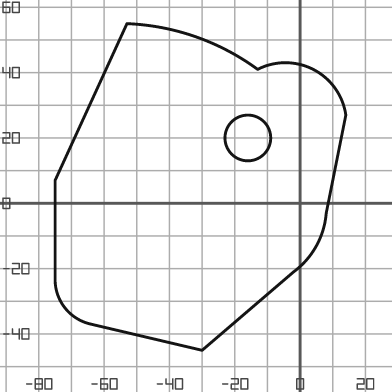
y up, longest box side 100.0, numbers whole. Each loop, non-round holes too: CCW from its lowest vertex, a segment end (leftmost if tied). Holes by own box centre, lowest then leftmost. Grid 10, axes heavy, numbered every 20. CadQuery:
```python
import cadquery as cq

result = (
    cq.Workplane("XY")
    .moveTo(-30.0, -45.0)
    .lineTo(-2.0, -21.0)
    .threePointArc((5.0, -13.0), (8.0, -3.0))
    .lineTo(14.0, 27.0)
    .threePointArc((4.0, 41.0), (-13.0, 41.0))
    .threePointArc((-32.0, 51.0), (-53.0, 55.0))
    .lineTo(-75.0, 7.0)
    .lineTo(-75.0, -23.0)
    .threePointArc((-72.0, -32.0), (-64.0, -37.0))
    .close()
    .moveTo(-16.0, 20.0)
    .circle(7.0)
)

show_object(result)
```